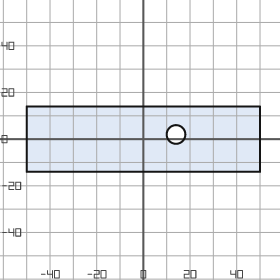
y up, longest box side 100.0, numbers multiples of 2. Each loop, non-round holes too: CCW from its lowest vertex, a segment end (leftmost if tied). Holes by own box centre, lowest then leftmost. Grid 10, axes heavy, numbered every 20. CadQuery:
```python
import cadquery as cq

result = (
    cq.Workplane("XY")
    .moveTo(-50.0, -14.0)
    .lineTo(50.0, -14.0)
    .lineTo(50.0, 14.0)
    .lineTo(-50.0, 14.0)
    .close()
    .moveTo(14.0, 2.0)
    .circle(4.0)
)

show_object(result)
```